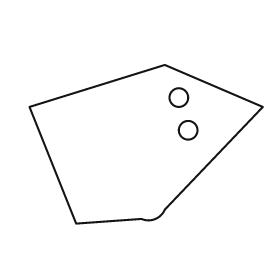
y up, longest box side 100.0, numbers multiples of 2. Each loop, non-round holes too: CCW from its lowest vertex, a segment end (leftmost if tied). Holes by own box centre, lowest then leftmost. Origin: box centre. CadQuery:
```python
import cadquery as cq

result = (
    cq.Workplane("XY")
    .moveTo(-30.0, -34.0)
    .lineTo(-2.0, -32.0)
    .threePointArc((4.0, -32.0), (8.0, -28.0))
    .lineTo(50.0, 16.0)
    .lineTo(8.0, 34.0)
    .lineTo(-50.0, 16.0)
    .close()
    .moveTo(18.0, 6.0)
    .circle(4.0)
    .moveTo(14.0, 20.0)
    .circle(4.0)
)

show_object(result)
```